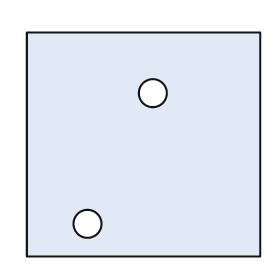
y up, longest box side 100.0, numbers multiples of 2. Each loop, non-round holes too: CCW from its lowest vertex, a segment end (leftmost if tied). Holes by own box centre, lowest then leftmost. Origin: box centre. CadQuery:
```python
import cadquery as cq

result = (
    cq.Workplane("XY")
    .moveTo(-50.0, -48.0)
    .lineTo(50.0, -48.0)
    .lineTo(50.0, 48.0)
    .lineTo(-50.0, 48.0)
    .close()
    .moveTo(-24.0, -34.0)
    .circle(6.0)
    .moveTo(4.0, 22.0)
    .circle(6.0)
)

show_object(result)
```